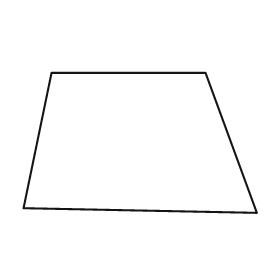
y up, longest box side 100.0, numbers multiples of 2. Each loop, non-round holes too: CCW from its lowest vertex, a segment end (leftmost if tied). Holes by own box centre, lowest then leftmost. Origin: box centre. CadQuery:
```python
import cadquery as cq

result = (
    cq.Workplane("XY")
    .moveTo(50.0, -30.0)
    .lineTo(28.0, 30.0)
    .lineTo(-38.0, 30.0)
    .lineTo(-50.0, -28.0)
    .close()
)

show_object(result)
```